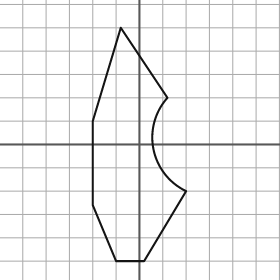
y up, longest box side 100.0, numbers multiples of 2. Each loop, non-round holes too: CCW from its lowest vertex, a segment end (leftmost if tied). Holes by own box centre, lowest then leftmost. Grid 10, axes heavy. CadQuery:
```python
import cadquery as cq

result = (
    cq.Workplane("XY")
    .moveTo(-10.0, -50.0)
    .lineTo(2.0, -50.0)
    .lineTo(20.0, -20.0)
    .threePointArc((6.0, -2.0), (12.0, 20.0))
    .lineTo(-8.0, 50.0)
    .lineTo(-20.0, 10.0)
    .lineTo(-20.0, -26.0)
    .close()
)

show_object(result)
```